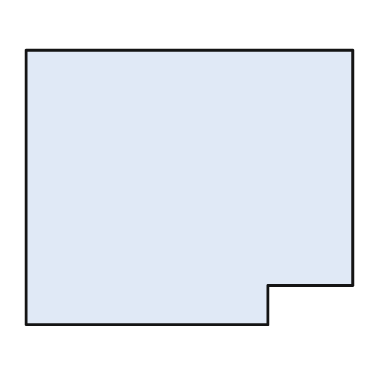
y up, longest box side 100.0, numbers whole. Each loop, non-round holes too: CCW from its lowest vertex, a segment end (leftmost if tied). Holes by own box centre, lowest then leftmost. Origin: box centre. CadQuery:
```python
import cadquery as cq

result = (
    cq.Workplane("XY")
    .moveTo(-50.0, -42.0)
    .lineTo(24.0, -42.0)
    .lineTo(24.0, -30.0)
    .lineTo(50.0, -30.0)
    .lineTo(50.0, 42.0)
    .lineTo(-50.0, 42.0)
    .close()
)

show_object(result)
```